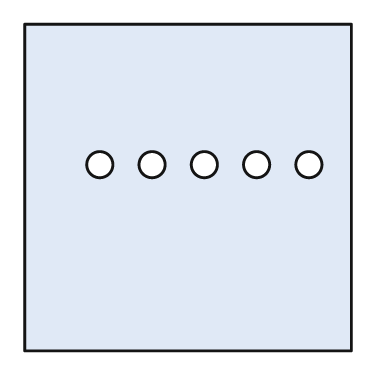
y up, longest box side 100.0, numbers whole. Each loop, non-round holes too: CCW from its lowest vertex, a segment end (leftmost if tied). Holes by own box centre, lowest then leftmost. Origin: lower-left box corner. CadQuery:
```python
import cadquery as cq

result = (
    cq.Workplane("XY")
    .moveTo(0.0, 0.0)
    .lineTo(100.0, 0.0)
    .lineTo(100.0, 100.0)
    .lineTo(0.0, 100.0)
    .close()
    .moveTo(23.0, 57.0)
    .circle(4.0)
    .moveTo(39.0, 57.0)
    .circle(4.0)
    .moveTo(55.0, 57.0)
    .circle(4.0)
    .moveTo(71.0, 57.0)
    .circle(4.0)
    .moveTo(87.0, 57.0)
    .circle(4.0)
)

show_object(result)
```